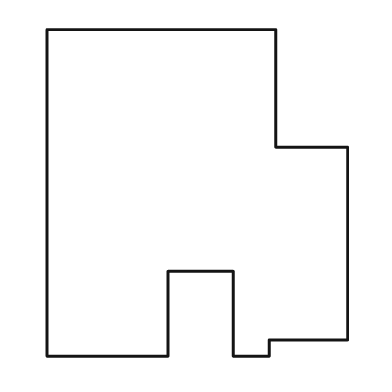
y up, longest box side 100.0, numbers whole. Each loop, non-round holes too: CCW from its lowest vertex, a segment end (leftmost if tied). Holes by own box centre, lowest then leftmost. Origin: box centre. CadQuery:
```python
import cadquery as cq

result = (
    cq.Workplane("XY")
    .moveTo(-46.0, -50.0)
    .lineTo(-9.0, -50.0)
    .lineTo(-9.0, -24.0)
    .lineTo(11.0, -24.0)
    .lineTo(11.0, -50.0)
    .lineTo(22.0, -50.0)
    .lineTo(22.0, -45.0)
    .lineTo(46.0, -45.0)
    .lineTo(46.0, 14.0)
    .lineTo(24.0, 14.0)
    .lineTo(24.0, 50.0)
    .lineTo(-46.0, 50.0)
    .close()
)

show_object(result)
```